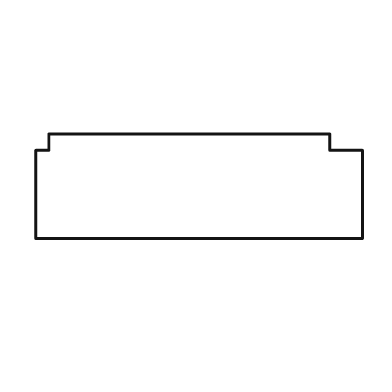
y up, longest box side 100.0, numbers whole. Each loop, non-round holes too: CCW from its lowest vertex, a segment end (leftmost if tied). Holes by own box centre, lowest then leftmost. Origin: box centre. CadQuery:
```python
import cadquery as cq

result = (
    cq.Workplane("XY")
    .moveTo(-50.0, -16.0)
    .lineTo(50.0, -16.0)
    .lineTo(50.0, 11.0)
    .lineTo(40.0, 11.0)
    .lineTo(40.0, 16.0)
    .lineTo(-46.0, 16.0)
    .lineTo(-46.0, 11.0)
    .lineTo(-50.0, 11.0)
    .close()
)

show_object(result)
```